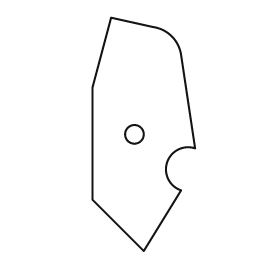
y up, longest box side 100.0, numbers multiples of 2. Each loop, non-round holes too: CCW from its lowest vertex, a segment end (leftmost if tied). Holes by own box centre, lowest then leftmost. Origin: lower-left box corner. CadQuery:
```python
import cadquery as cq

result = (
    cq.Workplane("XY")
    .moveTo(22.0, 0.0)
    .lineTo(38.0, 26.0)
    .threePointArc((32.0, 38.0), (44.0, 44.0))
    .lineTo(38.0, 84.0)
    .threePointArc((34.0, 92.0), (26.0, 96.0))
    .lineTo(8.0, 100.0)
    .lineTo(0.0, 70.0)
    .lineTo(0.0, 22.0)
    .close()
    .moveTo(18.0, 50.0)
    .circle(4.0)
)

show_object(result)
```